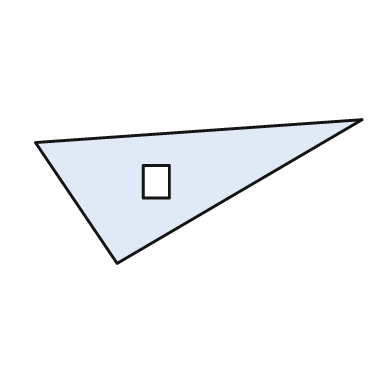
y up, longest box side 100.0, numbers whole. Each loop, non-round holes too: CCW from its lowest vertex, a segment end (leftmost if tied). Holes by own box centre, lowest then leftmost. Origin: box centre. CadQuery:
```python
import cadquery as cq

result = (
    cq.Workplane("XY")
    .moveTo(-25.0, -22.0)
    .lineTo(50.0, 22.0)
    .lineTo(-50.0, 15.0)
    .close()
    .moveTo(-17.0, -2.0)
    .lineTo(-9.0, -2.0)
    .lineTo(-9.0, 8.0)
    .lineTo(-17.0, 8.0)
    .close()
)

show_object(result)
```